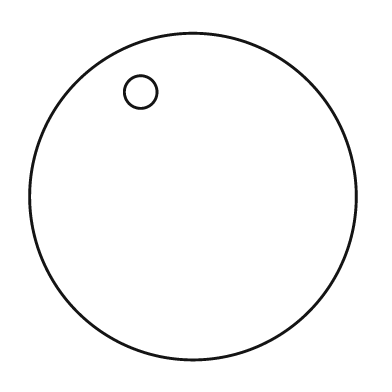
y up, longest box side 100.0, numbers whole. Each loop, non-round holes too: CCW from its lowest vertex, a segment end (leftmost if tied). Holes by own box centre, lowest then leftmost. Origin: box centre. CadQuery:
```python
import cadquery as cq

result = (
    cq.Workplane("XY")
    .moveTo(0.0, 0.0)
    .circle(50.0)
    .moveTo(-16.0, 32.0)
    .circle(5.0)
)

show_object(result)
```